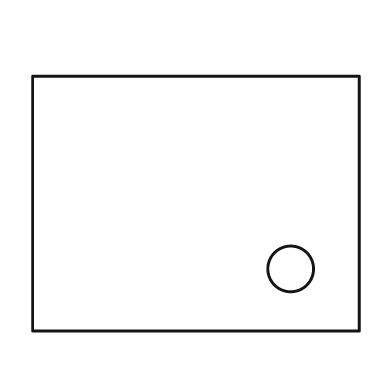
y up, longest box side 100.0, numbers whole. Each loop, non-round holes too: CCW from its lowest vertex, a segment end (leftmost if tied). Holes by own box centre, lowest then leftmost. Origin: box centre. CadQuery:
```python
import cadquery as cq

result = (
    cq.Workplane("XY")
    .moveTo(-50.0, -39.0)
    .lineTo(50.0, -39.0)
    .lineTo(50.0, 39.0)
    .lineTo(-50.0, 39.0)
    .close()
    .moveTo(29.0, -20.0)
    .circle(7.0)
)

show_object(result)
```